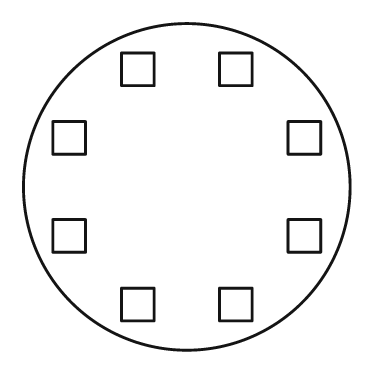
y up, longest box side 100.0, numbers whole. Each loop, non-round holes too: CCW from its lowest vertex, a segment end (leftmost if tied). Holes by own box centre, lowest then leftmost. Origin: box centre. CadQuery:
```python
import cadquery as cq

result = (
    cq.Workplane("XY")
    .moveTo(0.0, 0.0)
    .circle(50.0)
    .moveTo(-20.0, -41.0)
    .lineTo(-10.0, -41.0)
    .lineTo(-10.0, -31.0)
    .lineTo(-20.0, -31.0)
    .close()
    .moveTo(10.0, -41.0)
    .lineTo(20.0, -41.0)
    .lineTo(20.0, -31.0)
    .lineTo(10.0, -31.0)
    .close()
    .moveTo(-41.0, -20.0)
    .lineTo(-31.0, -20.0)
    .lineTo(-31.0, -10.0)
    .lineTo(-41.0, -10.0)
    .close()
    .moveTo(31.0, -20.0)
    .lineTo(41.0, -20.0)
    .lineTo(41.0, -10.0)
    .lineTo(31.0, -10.0)
    .close()
    .moveTo(-41.0, 10.0)
    .lineTo(-31.0, 10.0)
    .lineTo(-31.0, 20.0)
    .lineTo(-41.0, 20.0)
    .close()
    .moveTo(31.0, 10.0)
    .lineTo(41.0, 10.0)
    .lineTo(41.0, 20.0)
    .lineTo(31.0, 20.0)
    .close()
    .moveTo(-20.0, 31.0)
    .lineTo(-10.0, 31.0)
    .lineTo(-10.0, 41.0)
    .lineTo(-20.0, 41.0)
    .close()
    .moveTo(10.0, 31.0)
    .lineTo(20.0, 31.0)
    .lineTo(20.0, 41.0)
    .lineTo(10.0, 41.0)
    .close()
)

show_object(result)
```